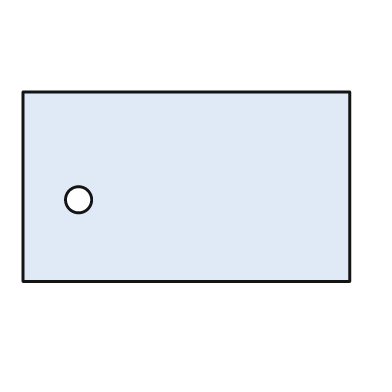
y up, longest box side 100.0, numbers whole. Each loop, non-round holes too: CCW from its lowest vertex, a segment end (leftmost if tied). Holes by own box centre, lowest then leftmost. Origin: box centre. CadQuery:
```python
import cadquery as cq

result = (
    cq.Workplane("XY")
    .moveTo(-50.0, -29.0)
    .lineTo(50.0, -29.0)
    .lineTo(50.0, 29.0)
    .lineTo(-50.0, 29.0)
    .close()
    .moveTo(-33.0, -4.0)
    .circle(4.0)
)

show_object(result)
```